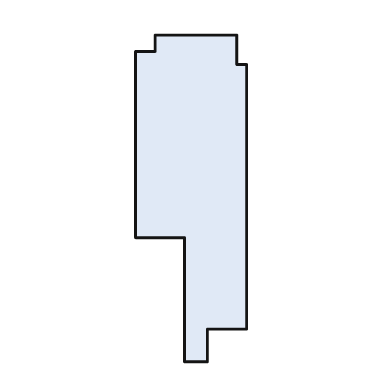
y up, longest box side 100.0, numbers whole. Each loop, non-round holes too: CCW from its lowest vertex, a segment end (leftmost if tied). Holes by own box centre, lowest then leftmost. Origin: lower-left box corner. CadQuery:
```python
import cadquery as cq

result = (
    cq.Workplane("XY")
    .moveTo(15.0, 0.0)
    .lineTo(22.0, 0.0)
    .lineTo(22.0, 10.0)
    .lineTo(34.0, 10.0)
    .lineTo(34.0, 91.0)
    .lineTo(31.0, 91.0)
    .lineTo(31.0, 100.0)
    .lineTo(6.0, 100.0)
    .lineTo(6.0, 95.0)
    .lineTo(0.0, 95.0)
    .lineTo(0.0, 38.0)
    .lineTo(15.0, 38.0)
    .close()
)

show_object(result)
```